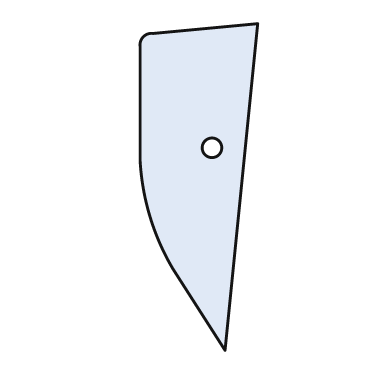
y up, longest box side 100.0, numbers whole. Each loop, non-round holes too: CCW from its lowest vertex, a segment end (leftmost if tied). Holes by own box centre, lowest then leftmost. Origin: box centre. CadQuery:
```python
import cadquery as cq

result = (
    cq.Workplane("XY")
    .moveTo(8.0, -50.0)
    .lineTo(18.0, 50.0)
    .lineTo(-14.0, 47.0)
    .threePointArc((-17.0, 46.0), (-18.0, 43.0))
    .lineTo(-18.0, 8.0)
    .threePointArc((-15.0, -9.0), (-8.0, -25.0))
    .close()
    .moveTo(4.0, 12.0)
    .circle(3.0)
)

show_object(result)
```